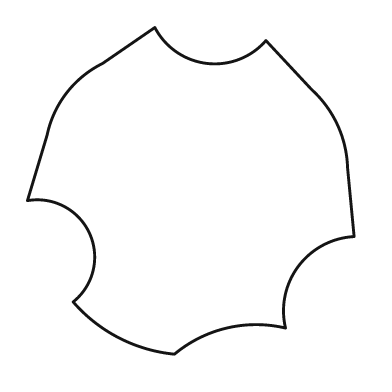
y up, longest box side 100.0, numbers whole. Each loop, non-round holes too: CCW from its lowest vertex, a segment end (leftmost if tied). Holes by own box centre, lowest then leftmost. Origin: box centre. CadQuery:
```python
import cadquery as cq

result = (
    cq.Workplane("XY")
    .moveTo(-5.0, -50.0)
    .threePointArc((11.0, -42.0), (29.0, -42.0))
    .threePointArc((33.0, -23.0), (50.0, -14.0))
    .lineTo(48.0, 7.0)
    .threePointArc((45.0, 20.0), (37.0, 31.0))
    .lineTo(23.0, 46.0)
    .threePointArc((5.0, 39.0), (-11.0, 50.0))
    .lineTo(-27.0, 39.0)
    .threePointArc((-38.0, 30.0), (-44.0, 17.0))
    .lineTo(-50.0, -3.0)
    .threePointArc((-31.0, -13.0), (-36.0, -34.0))
    .threePointArc((-22.0, -45.0), (-5.0, -50.0))
    .close()
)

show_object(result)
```